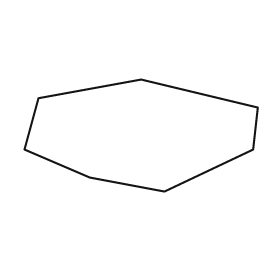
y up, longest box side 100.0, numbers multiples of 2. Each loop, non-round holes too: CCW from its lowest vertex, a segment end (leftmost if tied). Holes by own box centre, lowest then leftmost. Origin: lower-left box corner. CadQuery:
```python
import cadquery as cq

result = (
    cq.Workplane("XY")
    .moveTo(60.0, 0.0)
    .lineTo(98.0, 18.0)
    .lineTo(100.0, 36.0)
    .lineTo(50.0, 48.0)
    .lineTo(6.0, 40.0)
    .lineTo(0.0, 18.0)
    .lineTo(28.0, 6.0)
    .close()
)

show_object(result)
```